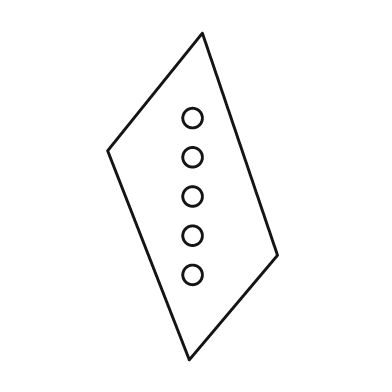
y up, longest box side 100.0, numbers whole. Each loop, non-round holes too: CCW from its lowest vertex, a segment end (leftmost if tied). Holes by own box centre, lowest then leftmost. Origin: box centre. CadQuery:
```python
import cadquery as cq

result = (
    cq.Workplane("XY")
    .moveTo(-1.0, -50.0)
    .lineTo(26.0, -18.0)
    .lineTo(3.0, 50.0)
    .lineTo(-26.0, 14.0)
    .close()
    .moveTo(0.0, -24.0)
    .circle(3.0)
    .moveTo(0.0, -12.0)
    .circle(3.0)
    .moveTo(0.0, 0.0)
    .circle(3.0)
    .moveTo(0.0, 12.0)
    .circle(3.0)
    .moveTo(0.0, 24.0)
    .circle(3.0)
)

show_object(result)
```